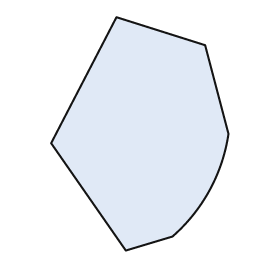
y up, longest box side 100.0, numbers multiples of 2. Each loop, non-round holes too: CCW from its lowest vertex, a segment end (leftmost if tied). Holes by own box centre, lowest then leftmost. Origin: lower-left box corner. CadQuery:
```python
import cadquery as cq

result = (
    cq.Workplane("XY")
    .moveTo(32.0, 0.0)
    .lineTo(52.0, 6.0)
    .threePointArc((68.0, 26.0), (76.0, 50.0))
    .lineTo(66.0, 88.0)
    .lineTo(28.0, 100.0)
    .lineTo(0.0, 46.0)
    .close()
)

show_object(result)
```